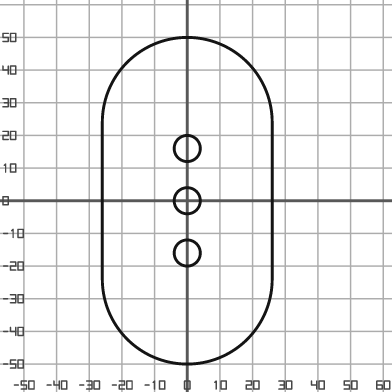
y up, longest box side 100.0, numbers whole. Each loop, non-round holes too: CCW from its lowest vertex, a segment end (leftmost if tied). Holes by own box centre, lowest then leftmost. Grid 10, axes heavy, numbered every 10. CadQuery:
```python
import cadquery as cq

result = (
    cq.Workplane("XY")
    .moveTo(-26.0, -24.0)
    .threePointArc((0.0, -50.0), (26.0, -24.0))
    .lineTo(26.0, 24.0)
    .threePointArc((0.0, 50.0), (-26.0, 24.0))
    .close()
    .moveTo(0.0, -16.0)
    .circle(4.0)
    .moveTo(0.0, 0.0)
    .circle(4.0)
    .moveTo(0.0, 16.0)
    .circle(4.0)
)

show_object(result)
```